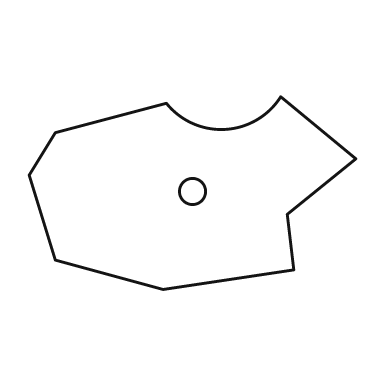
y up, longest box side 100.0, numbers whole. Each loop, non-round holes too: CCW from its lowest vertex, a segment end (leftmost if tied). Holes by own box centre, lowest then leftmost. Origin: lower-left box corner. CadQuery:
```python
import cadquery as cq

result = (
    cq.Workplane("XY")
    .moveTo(41.0, 0.0)
    .lineTo(81.0, 6.0)
    .lineTo(79.0, 23.0)
    .lineTo(100.0, 40.0)
    .lineTo(77.0, 59.0)
    .threePointArc((60.0, 49.0), (42.0, 57.0))
    .lineTo(8.0, 48.0)
    .lineTo(0.0, 35.0)
    .lineTo(8.0, 9.0)
    .close()
    .moveTo(50.0, 30.0)
    .circle(4.0)
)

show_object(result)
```